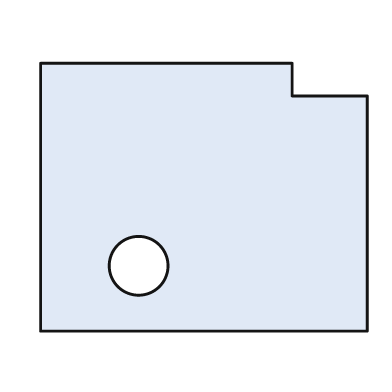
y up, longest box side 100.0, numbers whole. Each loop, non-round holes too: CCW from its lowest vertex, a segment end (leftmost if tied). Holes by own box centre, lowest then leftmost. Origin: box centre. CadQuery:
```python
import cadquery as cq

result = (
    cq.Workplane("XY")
    .moveTo(-50.0, -41.0)
    .lineTo(50.0, -41.0)
    .lineTo(50.0, 31.0)
    .lineTo(27.0, 31.0)
    .lineTo(27.0, 41.0)
    .lineTo(-50.0, 41.0)
    .close()
    .moveTo(-20.0, -21.0)
    .circle(9.0)
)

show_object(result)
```